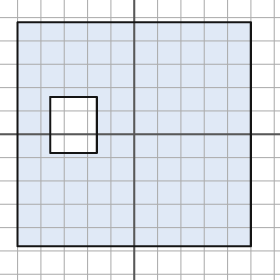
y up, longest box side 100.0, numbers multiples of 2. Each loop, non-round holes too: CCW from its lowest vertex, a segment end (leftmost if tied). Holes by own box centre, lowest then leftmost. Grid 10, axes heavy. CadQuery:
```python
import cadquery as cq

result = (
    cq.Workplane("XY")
    .moveTo(-50.0, -48.0)
    .lineTo(50.0, -48.0)
    .lineTo(50.0, 48.0)
    .lineTo(-50.0, 48.0)
    .close()
    .moveTo(-36.0, -8.0)
    .lineTo(-16.0, -8.0)
    .lineTo(-16.0, 16.0)
    .lineTo(-36.0, 16.0)
    .close()
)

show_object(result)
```